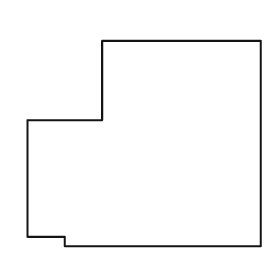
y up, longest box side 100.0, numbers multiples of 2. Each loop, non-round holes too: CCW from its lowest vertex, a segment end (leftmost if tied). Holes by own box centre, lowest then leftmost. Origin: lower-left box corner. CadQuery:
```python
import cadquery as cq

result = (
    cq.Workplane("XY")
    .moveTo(16.0, 0.0)
    .lineTo(100.0, 0.0)
    .lineTo(100.0, 88.0)
    .lineTo(32.0, 88.0)
    .lineTo(32.0, 54.0)
    .lineTo(0.0, 54.0)
    .lineTo(0.0, 4.0)
    .lineTo(16.0, 4.0)
    .close()
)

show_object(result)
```